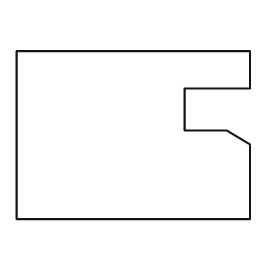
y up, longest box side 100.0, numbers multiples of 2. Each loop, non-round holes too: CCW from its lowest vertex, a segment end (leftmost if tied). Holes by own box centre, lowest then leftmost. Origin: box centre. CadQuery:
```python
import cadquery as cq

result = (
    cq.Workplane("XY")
    .moveTo(-50.0, -36.0)
    .lineTo(50.0, -36.0)
    .lineTo(50.0, -4.0)
    .lineTo(40.0, 2.0)
    .lineTo(22.0, 2.0)
    .lineTo(22.0, 20.0)
    .lineTo(50.0, 20.0)
    .lineTo(50.0, 36.0)
    .lineTo(-50.0, 36.0)
    .close()
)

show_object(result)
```